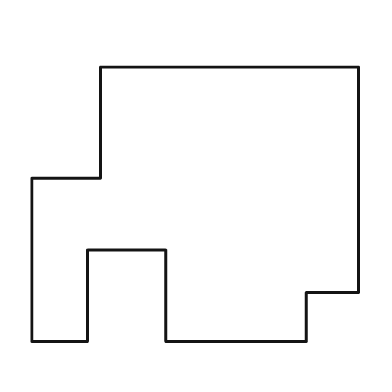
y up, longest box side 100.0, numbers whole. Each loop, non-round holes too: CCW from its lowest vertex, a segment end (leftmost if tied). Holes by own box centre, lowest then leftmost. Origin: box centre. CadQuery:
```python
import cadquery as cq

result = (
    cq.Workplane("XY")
    .moveTo(-50.0, -42.0)
    .lineTo(-33.0, -42.0)
    .lineTo(-33.0, -14.0)
    .lineTo(-9.0, -14.0)
    .lineTo(-9.0, -42.0)
    .lineTo(34.0, -42.0)
    .lineTo(34.0, -27.0)
    .lineTo(50.0, -27.0)
    .lineTo(50.0, 42.0)
    .lineTo(-29.0, 42.0)
    .lineTo(-29.0, 8.0)
    .lineTo(-50.0, 8.0)
    .close()
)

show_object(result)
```